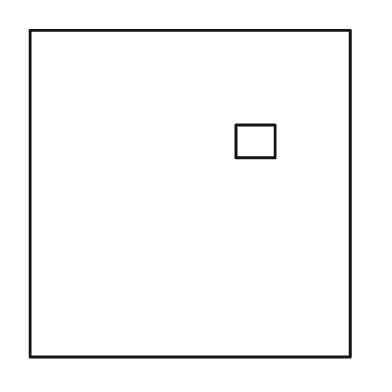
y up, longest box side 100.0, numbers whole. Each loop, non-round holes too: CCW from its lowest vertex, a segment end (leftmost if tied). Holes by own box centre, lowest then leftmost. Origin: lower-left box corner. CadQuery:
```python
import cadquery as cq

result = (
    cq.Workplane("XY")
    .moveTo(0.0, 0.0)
    .lineTo(98.0, 0.0)
    .lineTo(98.0, 100.0)
    .lineTo(0.0, 100.0)
    .close()
    .moveTo(63.0, 61.0)
    .lineTo(75.0, 61.0)
    .lineTo(75.0, 71.0)
    .lineTo(63.0, 71.0)
    .close()
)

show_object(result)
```